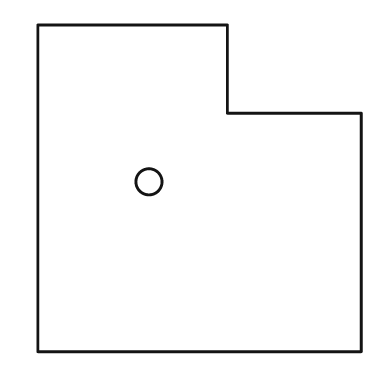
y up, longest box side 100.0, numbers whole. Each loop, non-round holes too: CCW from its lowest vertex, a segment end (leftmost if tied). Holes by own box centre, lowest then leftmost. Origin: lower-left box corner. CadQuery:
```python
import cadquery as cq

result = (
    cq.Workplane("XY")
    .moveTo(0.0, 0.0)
    .lineTo(99.0, 0.0)
    .lineTo(99.0, 73.0)
    .lineTo(58.0, 73.0)
    .lineTo(58.0, 100.0)
    .lineTo(0.0, 100.0)
    .close()
    .moveTo(34.0, 52.0)
    .circle(4.0)
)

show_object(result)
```